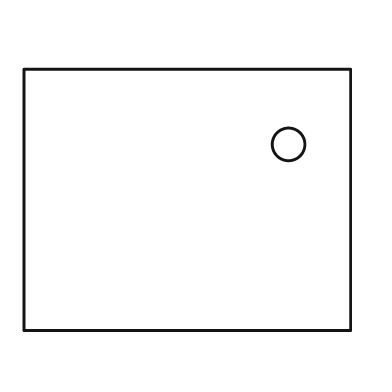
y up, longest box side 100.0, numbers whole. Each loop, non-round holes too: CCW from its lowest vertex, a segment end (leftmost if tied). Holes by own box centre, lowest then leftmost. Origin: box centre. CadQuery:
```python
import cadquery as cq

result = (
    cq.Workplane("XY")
    .moveTo(-50.0, -40.0)
    .lineTo(50.0, -40.0)
    .lineTo(50.0, 40.0)
    .lineTo(-50.0, 40.0)
    .close()
    .moveTo(31.0, 17.0)
    .circle(5.0)
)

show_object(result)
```